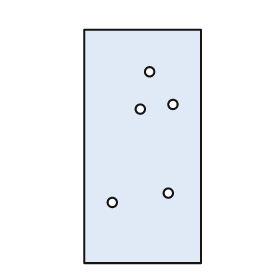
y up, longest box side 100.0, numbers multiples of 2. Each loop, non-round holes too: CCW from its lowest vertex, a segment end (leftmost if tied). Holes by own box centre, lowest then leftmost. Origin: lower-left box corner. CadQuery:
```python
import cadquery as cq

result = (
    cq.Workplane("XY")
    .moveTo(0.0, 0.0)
    .lineTo(50.0, 0.0)
    .lineTo(50.0, 100.0)
    .lineTo(0.0, 100.0)
    .close()
    .moveTo(12.0, 26.0)
    .circle(2.0)
    .moveTo(36.0, 30.0)
    .circle(2.0)
    .moveTo(24.0, 66.0)
    .circle(2.0)
    .moveTo(38.0, 68.0)
    .circle(2.0)
    .moveTo(28.0, 82.0)
    .circle(2.0)
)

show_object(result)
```